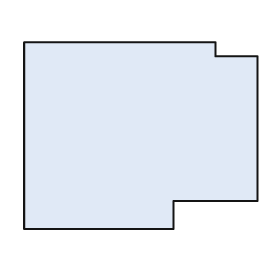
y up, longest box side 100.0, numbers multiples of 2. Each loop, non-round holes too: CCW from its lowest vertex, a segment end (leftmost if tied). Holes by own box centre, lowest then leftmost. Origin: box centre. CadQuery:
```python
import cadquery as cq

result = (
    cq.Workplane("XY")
    .moveTo(-50.0, -40.0)
    .lineTo(14.0, -40.0)
    .lineTo(14.0, -28.0)
    .lineTo(50.0, -28.0)
    .lineTo(50.0, 34.0)
    .lineTo(32.0, 34.0)
    .lineTo(32.0, 40.0)
    .lineTo(-50.0, 40.0)
    .close()
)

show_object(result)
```